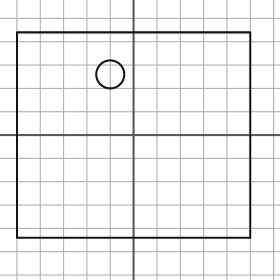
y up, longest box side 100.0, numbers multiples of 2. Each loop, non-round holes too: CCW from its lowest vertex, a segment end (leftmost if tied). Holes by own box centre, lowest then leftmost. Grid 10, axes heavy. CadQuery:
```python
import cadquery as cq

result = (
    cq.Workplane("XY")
    .moveTo(-50.0, -44.0)
    .lineTo(50.0, -44.0)
    .lineTo(50.0, 44.0)
    .lineTo(-50.0, 44.0)
    .close()
    .moveTo(-10.0, 26.0)
    .circle(6.0)
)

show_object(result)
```